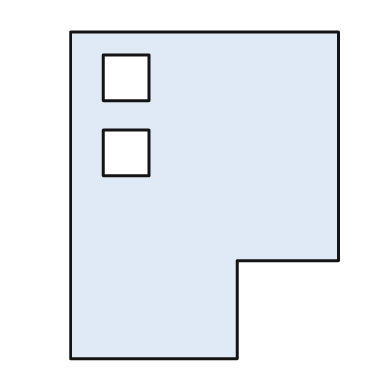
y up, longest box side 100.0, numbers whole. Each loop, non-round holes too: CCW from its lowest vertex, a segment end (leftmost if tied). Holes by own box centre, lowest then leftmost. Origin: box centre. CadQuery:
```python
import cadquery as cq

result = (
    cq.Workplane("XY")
    .moveTo(-41.0, -50.0)
    .lineTo(10.0, -50.0)
    .lineTo(10.0, -20.0)
    .lineTo(41.0, -20.0)
    .lineTo(41.0, 50.0)
    .lineTo(-41.0, 50.0)
    .close()
    .moveTo(-31.0, 6.0)
    .lineTo(-17.0, 6.0)
    .lineTo(-17.0, 20.0)
    .lineTo(-31.0, 20.0)
    .close()
    .moveTo(-31.0, 29.0)
    .lineTo(-17.0, 29.0)
    .lineTo(-17.0, 43.0)
    .lineTo(-31.0, 43.0)
    .close()
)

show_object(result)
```